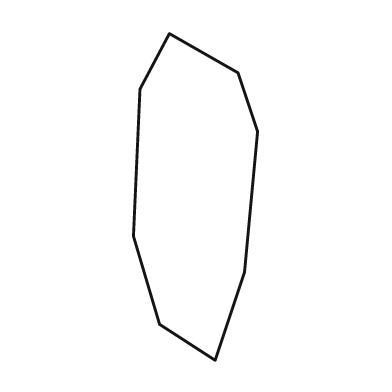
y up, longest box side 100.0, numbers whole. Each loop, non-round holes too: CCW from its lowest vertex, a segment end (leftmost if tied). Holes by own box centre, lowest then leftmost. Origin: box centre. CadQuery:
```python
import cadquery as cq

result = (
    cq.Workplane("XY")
    .moveTo(6.0, -50.0)
    .lineTo(15.0, -23.0)
    .lineTo(19.0, 20.0)
    .lineTo(13.0, 38.0)
    .lineTo(-8.0, 50.0)
    .lineTo(-17.0, 33.0)
    .lineTo(-19.0, -12.0)
    .lineTo(-11.0, -39.0)
    .close()
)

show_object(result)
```